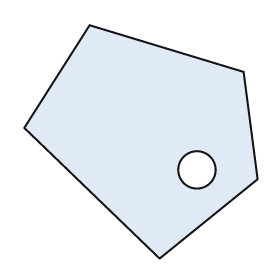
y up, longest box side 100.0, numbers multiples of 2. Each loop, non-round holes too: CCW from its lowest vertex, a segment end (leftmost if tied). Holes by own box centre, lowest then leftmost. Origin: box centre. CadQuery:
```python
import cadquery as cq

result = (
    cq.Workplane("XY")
    .moveTo(8.0, -50.0)
    .lineTo(50.0, -16.0)
    .lineTo(44.0, 30.0)
    .lineTo(-22.0, 50.0)
    .lineTo(-50.0, 6.0)
    .close()
    .moveTo(24.0, -12.0)
    .circle(8.0)
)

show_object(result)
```